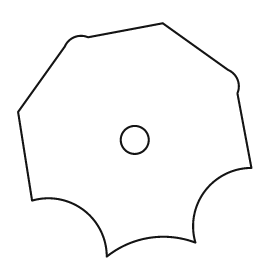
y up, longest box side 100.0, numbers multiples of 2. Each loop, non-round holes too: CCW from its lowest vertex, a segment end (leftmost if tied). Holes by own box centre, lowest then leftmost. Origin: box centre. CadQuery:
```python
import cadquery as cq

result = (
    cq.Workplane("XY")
    .moveTo(-12.0, -50.0)
    .threePointArc((6.0, -42.0), (26.0, -44.0))
    .threePointArc((30.0, -22.0), (50.0, -12.0))
    .lineTo(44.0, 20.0)
    .threePointArc((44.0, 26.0), (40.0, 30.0))
    .lineTo(12.0, 50.0)
    .lineTo(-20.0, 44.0)
    .threePointArc((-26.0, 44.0), (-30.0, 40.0))
    .lineTo(-50.0, 12.0)
    .lineTo(-44.0, -26.0)
    .threePointArc((-22.0, -30.0), (-12.0, -50.0))
    .close()
    .moveTo(0.0, 0.0)
    .circle(6.0)
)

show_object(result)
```